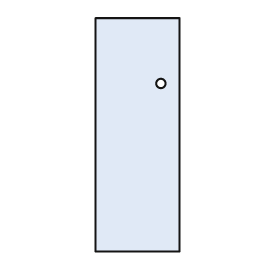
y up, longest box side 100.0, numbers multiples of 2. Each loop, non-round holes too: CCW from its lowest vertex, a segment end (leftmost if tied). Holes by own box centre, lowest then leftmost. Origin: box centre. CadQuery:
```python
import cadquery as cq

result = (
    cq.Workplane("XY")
    .moveTo(-18.0, -50.0)
    .lineTo(18.0, -50.0)
    .lineTo(18.0, 50.0)
    .lineTo(-18.0, 50.0)
    .close()
    .moveTo(10.0, 22.0)
    .circle(2.0)
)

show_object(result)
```